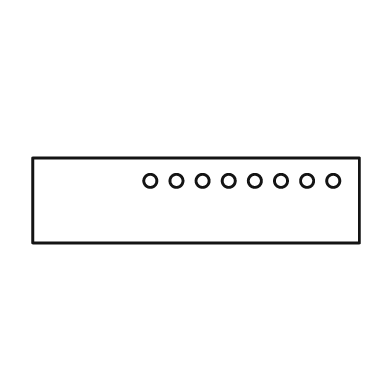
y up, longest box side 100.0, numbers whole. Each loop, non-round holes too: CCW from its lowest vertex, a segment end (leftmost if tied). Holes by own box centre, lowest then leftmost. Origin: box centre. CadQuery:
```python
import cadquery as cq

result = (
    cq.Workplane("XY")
    .moveTo(-50.0, -13.0)
    .lineTo(50.0, -13.0)
    .lineTo(50.0, 13.0)
    .lineTo(-50.0, 13.0)
    .close()
    .moveTo(-14.0, 6.0)
    .circle(2.0)
    .moveTo(-6.0, 6.0)
    .circle(2.0)
    .moveTo(2.0, 6.0)
    .circle(2.0)
    .moveTo(10.0, 6.0)
    .circle(2.0)
    .moveTo(18.0, 6.0)
    .circle(2.0)
    .moveTo(26.0, 6.0)
    .circle(2.0)
    .moveTo(34.0, 6.0)
    .circle(2.0)
    .moveTo(42.0, 6.0)
    .circle(2.0)
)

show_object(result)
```